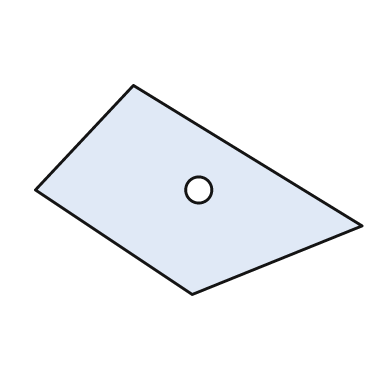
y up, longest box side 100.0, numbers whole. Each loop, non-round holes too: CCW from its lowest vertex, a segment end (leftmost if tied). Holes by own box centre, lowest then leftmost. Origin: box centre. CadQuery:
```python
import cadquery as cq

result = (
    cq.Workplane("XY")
    .moveTo(-2.0, -32.0)
    .lineTo(50.0, -11.0)
    .lineTo(-20.0, 32.0)
    .lineTo(-50.0, 0.0)
    .close()
    .moveTo(0.0, 0.0)
    .circle(4.0)
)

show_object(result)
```